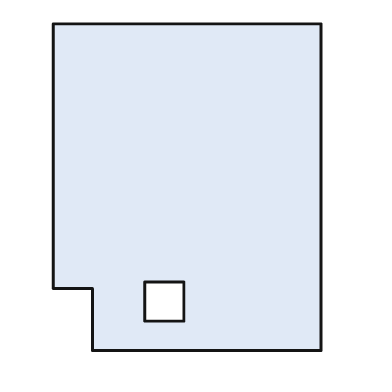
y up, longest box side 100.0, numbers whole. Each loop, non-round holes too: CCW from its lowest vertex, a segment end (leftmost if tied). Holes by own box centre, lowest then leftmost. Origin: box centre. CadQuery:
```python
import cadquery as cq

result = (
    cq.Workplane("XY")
    .moveTo(-29.0, -50.0)
    .lineTo(41.0, -50.0)
    .lineTo(41.0, 50.0)
    .lineTo(-41.0, 50.0)
    .lineTo(-41.0, -31.0)
    .lineTo(-29.0, -31.0)
    .close()
    .moveTo(-13.0, -41.0)
    .lineTo(-1.0, -41.0)
    .lineTo(-1.0, -29.0)
    .lineTo(-13.0, -29.0)
    .close()
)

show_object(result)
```